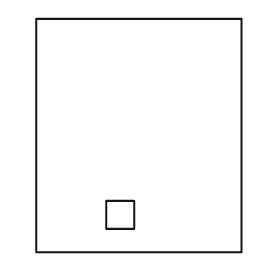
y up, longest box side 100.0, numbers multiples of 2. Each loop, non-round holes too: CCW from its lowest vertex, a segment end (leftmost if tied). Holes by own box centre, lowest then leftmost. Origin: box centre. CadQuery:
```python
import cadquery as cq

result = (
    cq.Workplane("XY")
    .moveTo(-44.0, -50.0)
    .lineTo(44.0, -50.0)
    .lineTo(44.0, 50.0)
    .lineTo(-44.0, 50.0)
    .close()
    .moveTo(-14.0, -40.0)
    .lineTo(-2.0, -40.0)
    .lineTo(-2.0, -28.0)
    .lineTo(-14.0, -28.0)
    .close()
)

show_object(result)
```